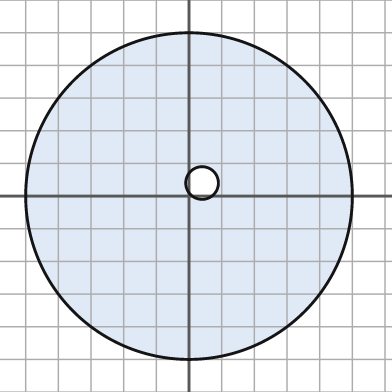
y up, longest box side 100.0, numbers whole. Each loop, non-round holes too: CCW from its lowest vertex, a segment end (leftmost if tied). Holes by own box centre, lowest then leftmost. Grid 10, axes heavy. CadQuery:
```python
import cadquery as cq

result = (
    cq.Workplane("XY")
    .moveTo(0.0, 0.0)
    .circle(50.0)
    .moveTo(4.0, 4.0)
    .circle(5.0)
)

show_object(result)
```